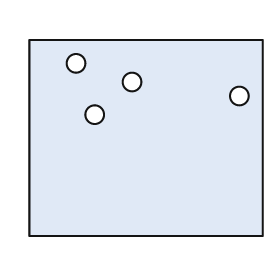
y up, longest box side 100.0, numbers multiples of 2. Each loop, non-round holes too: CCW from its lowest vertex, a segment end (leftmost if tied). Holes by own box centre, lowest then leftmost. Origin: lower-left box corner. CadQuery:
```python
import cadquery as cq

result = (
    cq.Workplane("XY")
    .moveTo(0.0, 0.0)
    .lineTo(100.0, 0.0)
    .lineTo(100.0, 84.0)
    .lineTo(0.0, 84.0)
    .close()
    .moveTo(28.0, 52.0)
    .circle(4.0)
    .moveTo(90.0, 60.0)
    .circle(4.0)
    .moveTo(44.0, 66.0)
    .circle(4.0)
    .moveTo(20.0, 74.0)
    .circle(4.0)
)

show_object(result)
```